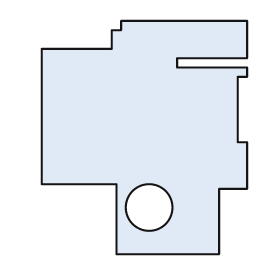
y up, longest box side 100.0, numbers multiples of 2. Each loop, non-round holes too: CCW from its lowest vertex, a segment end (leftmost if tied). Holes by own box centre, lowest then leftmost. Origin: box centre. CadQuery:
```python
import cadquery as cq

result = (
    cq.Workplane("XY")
    .moveTo(-12.0, -50.0)
    .lineTo(32.0, -50.0)
    .lineTo(32.0, -22.0)
    .lineTo(44.0, -22.0)
    .lineTo(44.0, -2.0)
    .lineTo(40.0, -2.0)
    .lineTo(40.0, 26.0)
    .lineTo(44.0, 26.0)
    .lineTo(44.0, 30.0)
    .lineTo(14.0, 30.0)
    .lineTo(14.0, 34.0)
    .lineTo(44.0, 34.0)
    .lineTo(44.0, 50.0)
    .lineTo(-10.0, 50.0)
    .lineTo(-10.0, 46.0)
    .lineTo(-14.0, 46.0)
    .lineTo(-14.0, 38.0)
    .lineTo(-44.0, 38.0)
    .lineTo(-44.0, -20.0)
    .lineTo(-12.0, -20.0)
    .close()
    .moveTo(2.0, -30.0)
    .circle(10.0)
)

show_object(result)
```